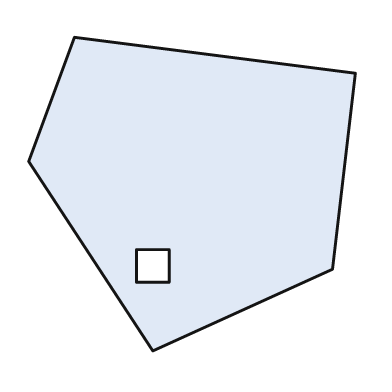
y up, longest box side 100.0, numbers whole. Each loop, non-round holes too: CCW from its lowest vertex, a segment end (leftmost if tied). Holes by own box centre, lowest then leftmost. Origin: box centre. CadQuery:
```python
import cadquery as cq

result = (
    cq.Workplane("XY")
    .moveTo(-12.0, -48.0)
    .lineTo(43.0, -23.0)
    .lineTo(50.0, 37.0)
    .lineTo(-36.0, 48.0)
    .lineTo(-50.0, 10.0)
    .close()
    .moveTo(-17.0, -27.0)
    .lineTo(-7.0, -27.0)
    .lineTo(-7.0, -17.0)
    .lineTo(-17.0, -17.0)
    .close()
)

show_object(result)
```